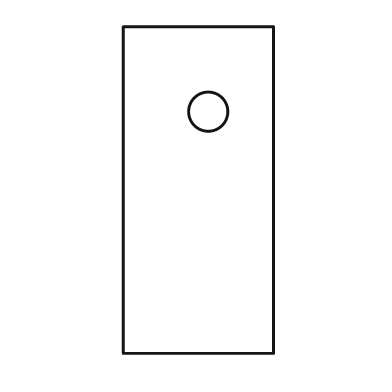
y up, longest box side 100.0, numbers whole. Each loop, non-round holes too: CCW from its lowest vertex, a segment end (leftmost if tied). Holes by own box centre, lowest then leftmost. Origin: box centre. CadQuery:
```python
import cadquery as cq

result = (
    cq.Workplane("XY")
    .moveTo(-23.0, -50.0)
    .lineTo(23.0, -50.0)
    .lineTo(23.0, 50.0)
    .lineTo(-23.0, 50.0)
    .close()
    .moveTo(3.0, 24.0)
    .circle(6.0)
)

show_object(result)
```